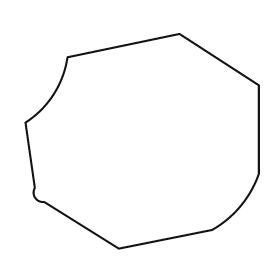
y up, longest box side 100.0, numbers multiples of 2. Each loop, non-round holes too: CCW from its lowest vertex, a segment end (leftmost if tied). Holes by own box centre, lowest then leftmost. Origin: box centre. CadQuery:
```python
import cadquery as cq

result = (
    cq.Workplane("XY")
    .moveTo(-10.0, -46.0)
    .lineTo(30.0, -38.0)
    .threePointArc((42.0, -28.0), (50.0, -14.0))
    .lineTo(50.0, 24.0)
    .lineTo(16.0, 46.0)
    .lineTo(-32.0, 36.0)
    .threePointArc((-38.0, 20.0), (-50.0, 8.0))
    .lineTo(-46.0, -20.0)
    .threePointArc((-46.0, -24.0), (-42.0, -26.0))
    .close()
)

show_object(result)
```